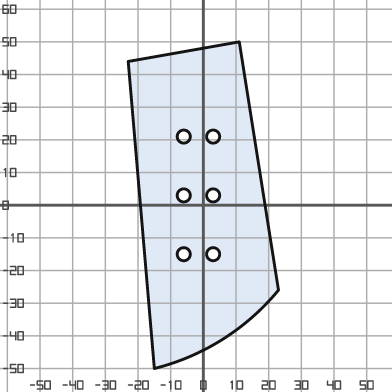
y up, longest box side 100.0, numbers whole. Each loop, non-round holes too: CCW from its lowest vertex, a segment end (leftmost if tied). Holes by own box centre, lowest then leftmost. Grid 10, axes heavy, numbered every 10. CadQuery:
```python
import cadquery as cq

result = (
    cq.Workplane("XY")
    .moveTo(-15.0, -50.0)
    .threePointArc((6.0, -41.0), (23.0, -26.0))
    .lineTo(11.0, 50.0)
    .lineTo(-23.0, 44.0)
    .close()
    .moveTo(-6.0, -15.0)
    .circle(2.0)
    .moveTo(3.0, -15.0)
    .circle(2.0)
    .moveTo(-6.0, 3.0)
    .circle(2.0)
    .moveTo(3.0, 3.0)
    .circle(2.0)
    .moveTo(-6.0, 21.0)
    .circle(2.0)
    .moveTo(3.0, 21.0)
    .circle(2.0)
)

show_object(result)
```